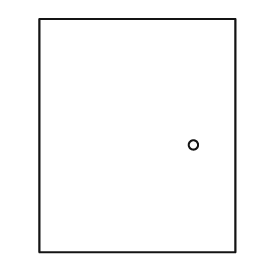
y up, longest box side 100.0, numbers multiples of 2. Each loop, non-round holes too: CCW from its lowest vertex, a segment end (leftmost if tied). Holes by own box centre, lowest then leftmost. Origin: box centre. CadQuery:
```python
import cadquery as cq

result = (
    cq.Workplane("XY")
    .moveTo(-42.0, -50.0)
    .lineTo(42.0, -50.0)
    .lineTo(42.0, 50.0)
    .lineTo(-42.0, 50.0)
    .close()
    .moveTo(24.0, -4.0)
    .circle(2.0)
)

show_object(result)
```